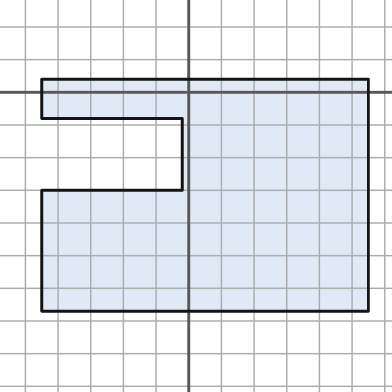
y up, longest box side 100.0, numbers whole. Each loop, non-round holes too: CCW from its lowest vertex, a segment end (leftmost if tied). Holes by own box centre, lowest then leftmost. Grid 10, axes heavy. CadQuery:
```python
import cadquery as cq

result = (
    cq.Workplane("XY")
    .moveTo(-45.0, -67.0)
    .lineTo(55.0, -67.0)
    .lineTo(55.0, 4.0)
    .lineTo(-45.0, 4.0)
    .lineTo(-45.0, -8.0)
    .lineTo(-2.0, -8.0)
    .lineTo(-2.0, -30.0)
    .lineTo(-45.0, -30.0)
    .close()
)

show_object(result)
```